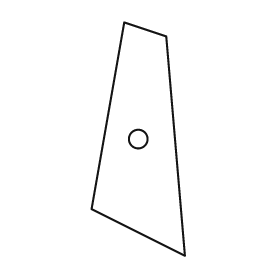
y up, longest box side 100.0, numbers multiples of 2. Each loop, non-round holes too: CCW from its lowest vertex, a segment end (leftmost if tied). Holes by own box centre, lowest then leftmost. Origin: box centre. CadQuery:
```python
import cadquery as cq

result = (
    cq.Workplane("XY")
    .moveTo(20.0, -50.0)
    .lineTo(12.0, 44.0)
    .lineTo(-6.0, 50.0)
    .lineTo(-20.0, -30.0)
    .close()
    .moveTo(0.0, 0.0)
    .circle(4.0)
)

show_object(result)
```